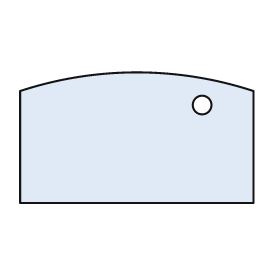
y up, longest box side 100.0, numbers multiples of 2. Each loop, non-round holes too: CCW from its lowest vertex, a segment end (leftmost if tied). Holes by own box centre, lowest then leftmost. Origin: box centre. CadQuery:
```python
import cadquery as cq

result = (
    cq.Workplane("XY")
    .moveTo(-50.0, -28.0)
    .lineTo(50.0, -28.0)
    .lineTo(50.0, 20.0)
    .threePointArc((0.0, 28.0), (-50.0, 20.0))
    .close()
    .moveTo(28.0, 14.0)
    .circle(4.0)
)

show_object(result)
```